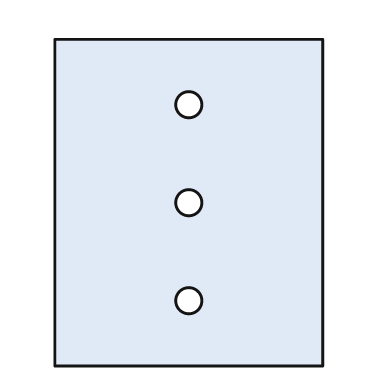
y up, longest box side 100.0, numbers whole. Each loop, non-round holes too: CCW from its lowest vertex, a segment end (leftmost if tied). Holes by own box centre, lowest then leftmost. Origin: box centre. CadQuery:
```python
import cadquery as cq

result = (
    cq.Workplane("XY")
    .moveTo(-41.0, -50.0)
    .lineTo(41.0, -50.0)
    .lineTo(41.0, 50.0)
    .lineTo(-41.0, 50.0)
    .close()
    .moveTo(0.0, -30.0)
    .circle(4.0)
    .moveTo(0.0, 0.0)
    .circle(4.0)
    .moveTo(0.0, 30.0)
    .circle(4.0)
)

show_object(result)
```